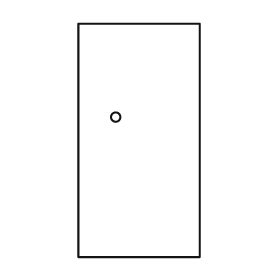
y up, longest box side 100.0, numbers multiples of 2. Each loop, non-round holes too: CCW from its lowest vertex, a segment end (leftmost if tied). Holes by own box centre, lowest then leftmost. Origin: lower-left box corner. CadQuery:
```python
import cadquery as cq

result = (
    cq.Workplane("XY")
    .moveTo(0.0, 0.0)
    .lineTo(52.0, 0.0)
    .lineTo(52.0, 100.0)
    .lineTo(0.0, 100.0)
    .close()
    .moveTo(16.0, 60.0)
    .circle(2.0)
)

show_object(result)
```